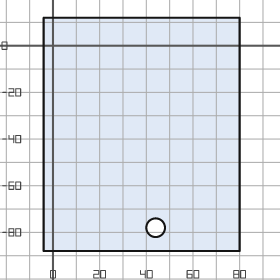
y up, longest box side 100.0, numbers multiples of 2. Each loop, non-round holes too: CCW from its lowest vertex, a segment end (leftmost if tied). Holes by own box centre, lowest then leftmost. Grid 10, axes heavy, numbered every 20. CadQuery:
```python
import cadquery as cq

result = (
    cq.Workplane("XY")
    .moveTo(-4.0, -88.0)
    .lineTo(80.0, -88.0)
    .lineTo(80.0, 12.0)
    .lineTo(-4.0, 12.0)
    .close()
    .moveTo(44.0, -78.0)
    .circle(4.0)
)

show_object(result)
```